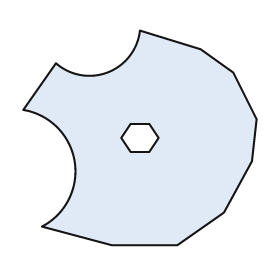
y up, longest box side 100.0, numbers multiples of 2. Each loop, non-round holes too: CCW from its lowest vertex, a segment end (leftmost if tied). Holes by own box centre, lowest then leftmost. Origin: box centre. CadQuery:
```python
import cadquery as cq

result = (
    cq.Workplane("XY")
    .moveTo(-12.0, -46.0)
    .lineTo(16.0, -46.0)
    .lineTo(36.0, -32.0)
    .lineTo(48.0, -10.0)
    .lineTo(50.0, 8.0)
    .lineTo(40.0, 28.0)
    .lineTo(26.0, 38.0)
    .lineTo(0.0, 46.0)
    .threePointArc((-14.0, 28.0), (-36.0, 32.0))
    .lineTo(-50.0, 12.0)
    .threePointArc((-28.0, -10.0), (-42.0, -38.0))
    .close()
    .moveTo(-4.0, -6.0)
    .lineTo(4.0, -6.0)
    .lineTo(8.0, 0.0)
    .lineTo(4.0, 6.0)
    .lineTo(-4.0, 6.0)
    .lineTo(-8.0, 0.0)
    .close()
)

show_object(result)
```